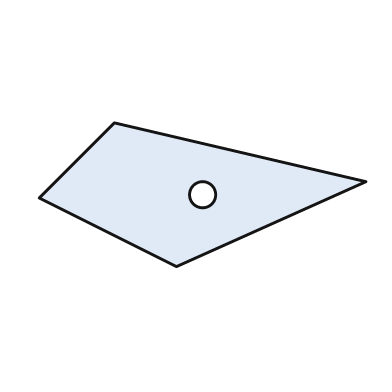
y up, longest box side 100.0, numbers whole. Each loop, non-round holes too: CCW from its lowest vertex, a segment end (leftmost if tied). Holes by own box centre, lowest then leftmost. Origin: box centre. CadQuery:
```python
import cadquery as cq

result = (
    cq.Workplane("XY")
    .moveTo(-8.0, -22.0)
    .lineTo(50.0, 4.0)
    .lineTo(-27.0, 22.0)
    .lineTo(-50.0, -1.0)
    .close()
    .moveTo(0.0, 0.0)
    .circle(4.0)
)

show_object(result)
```